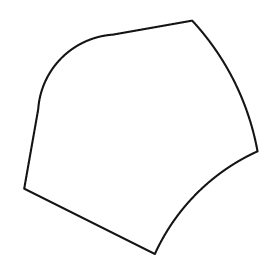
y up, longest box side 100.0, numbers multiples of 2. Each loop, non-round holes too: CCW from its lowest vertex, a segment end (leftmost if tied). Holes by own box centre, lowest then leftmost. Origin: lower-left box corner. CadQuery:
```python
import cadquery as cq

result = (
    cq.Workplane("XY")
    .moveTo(56.0, 0.0)
    .threePointArc((74.0, 26.0), (100.0, 44.0))
    .threePointArc((90.0, 74.0), (72.0, 100.0))
    .lineTo(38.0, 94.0)
    .threePointArc((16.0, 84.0), (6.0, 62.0))
    .lineTo(0.0, 28.0)
    .close()
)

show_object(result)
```